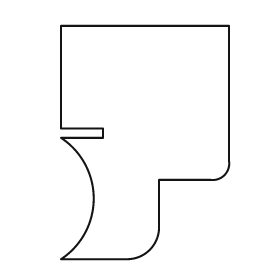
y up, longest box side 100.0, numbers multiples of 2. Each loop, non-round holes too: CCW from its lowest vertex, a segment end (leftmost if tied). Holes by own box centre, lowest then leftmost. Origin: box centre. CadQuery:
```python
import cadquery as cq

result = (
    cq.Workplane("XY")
    .moveTo(-36.0, -50.0)
    .lineTo(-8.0, -50.0)
    .threePointArc((2.0, -46.0), (6.0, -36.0))
    .lineTo(6.0, -16.0)
    .lineTo(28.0, -16.0)
    .threePointArc((34.0, -14.0), (36.0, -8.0))
    .lineTo(36.0, 50.0)
    .lineTo(-36.0, 50.0)
    .lineTo(-36.0, 6.0)
    .lineTo(-18.0, 6.0)
    .lineTo(-18.0, 2.0)
    .lineTo(-36.0, 2.0)
    .threePointArc((-22.0, -24.0), (-36.0, -50.0))
    .close()
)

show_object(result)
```